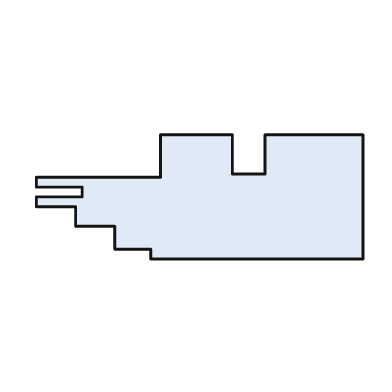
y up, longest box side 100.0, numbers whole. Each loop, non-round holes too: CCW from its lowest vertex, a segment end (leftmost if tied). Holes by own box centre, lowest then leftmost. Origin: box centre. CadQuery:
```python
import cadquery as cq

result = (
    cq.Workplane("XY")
    .moveTo(-15.0, -19.0)
    .lineTo(50.0, -19.0)
    .lineTo(50.0, 19.0)
    .lineTo(20.0, 19.0)
    .lineTo(20.0, 7.0)
    .lineTo(10.0, 7.0)
    .lineTo(10.0, 19.0)
    .lineTo(-12.0, 19.0)
    .lineTo(-12.0, 6.0)
    .lineTo(-50.0, 6.0)
    .lineTo(-50.0, 3.0)
    .lineTo(-36.0, 3.0)
    .lineTo(-36.0, 0.0)
    .lineTo(-50.0, 0.0)
    .lineTo(-50.0, -3.0)
    .lineTo(-38.0, -3.0)
    .lineTo(-38.0, -9.0)
    .lineTo(-26.0, -9.0)
    .lineTo(-26.0, -16.0)
    .lineTo(-15.0, -16.0)
    .close()
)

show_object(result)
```